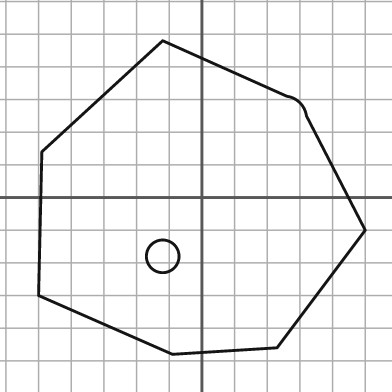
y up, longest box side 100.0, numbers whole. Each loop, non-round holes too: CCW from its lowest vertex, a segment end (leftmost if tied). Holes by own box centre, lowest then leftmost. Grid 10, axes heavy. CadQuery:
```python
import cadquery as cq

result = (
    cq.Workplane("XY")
    .moveTo(-9.0, -48.0)
    .lineTo(23.0, -46.0)
    .lineTo(50.0, -10.0)
    .lineTo(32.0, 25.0)
    .threePointArc((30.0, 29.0), (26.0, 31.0))
    .lineTo(-12.0, 48.0)
    .lineTo(-49.0, 14.0)
    .lineTo(-50.0, -30.0)
    .close()
    .moveTo(-12.0, -18.0)
    .circle(5.0)
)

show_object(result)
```